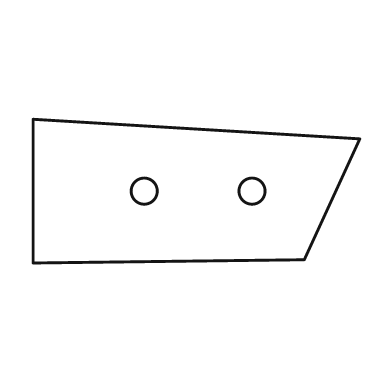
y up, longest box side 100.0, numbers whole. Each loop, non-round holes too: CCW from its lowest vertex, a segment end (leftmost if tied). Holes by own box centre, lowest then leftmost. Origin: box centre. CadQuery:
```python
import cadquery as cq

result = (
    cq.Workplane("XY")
    .moveTo(-50.0, -22.0)
    .lineTo(33.0, -21.0)
    .lineTo(50.0, 16.0)
    .lineTo(-50.0, 22.0)
    .close()
    .moveTo(-16.0, 0.0)
    .circle(4.0)
    .moveTo(17.0, 0.0)
    .circle(4.0)
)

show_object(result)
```